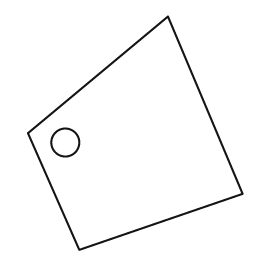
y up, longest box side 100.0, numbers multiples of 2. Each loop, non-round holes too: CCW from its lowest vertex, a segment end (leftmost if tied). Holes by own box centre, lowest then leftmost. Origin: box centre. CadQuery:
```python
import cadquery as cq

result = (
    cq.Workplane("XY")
    .moveTo(-24.0, -50.0)
    .lineTo(46.0, -26.0)
    .lineTo(14.0, 50.0)
    .lineTo(-46.0, 0.0)
    .close()
    .moveTo(-30.0, -4.0)
    .circle(6.0)
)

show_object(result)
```